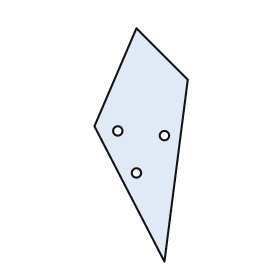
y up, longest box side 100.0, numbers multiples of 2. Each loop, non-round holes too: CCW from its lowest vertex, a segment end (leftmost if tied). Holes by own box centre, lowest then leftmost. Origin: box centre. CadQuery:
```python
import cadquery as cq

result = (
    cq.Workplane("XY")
    .moveTo(10.0, -50.0)
    .lineTo(20.0, 28.0)
    .lineTo(-2.0, 50.0)
    .lineTo(-20.0, 8.0)
    .close()
    .moveTo(-2.0, -12.0)
    .circle(2.0)
    .moveTo(10.0, 4.0)
    .circle(2.0)
    .moveTo(-10.0, 6.0)
    .circle(2.0)
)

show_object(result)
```